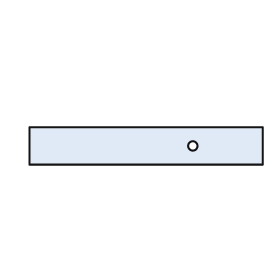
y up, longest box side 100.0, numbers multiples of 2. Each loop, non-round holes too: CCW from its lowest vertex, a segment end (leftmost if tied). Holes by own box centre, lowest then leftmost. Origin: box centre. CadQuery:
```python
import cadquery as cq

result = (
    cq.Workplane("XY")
    .moveTo(-50.0, -8.0)
    .lineTo(50.0, -8.0)
    .lineTo(50.0, 8.0)
    .lineTo(-50.0, 8.0)
    .close()
    .moveTo(20.0, 0.0)
    .circle(2.0)
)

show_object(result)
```